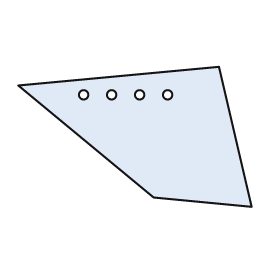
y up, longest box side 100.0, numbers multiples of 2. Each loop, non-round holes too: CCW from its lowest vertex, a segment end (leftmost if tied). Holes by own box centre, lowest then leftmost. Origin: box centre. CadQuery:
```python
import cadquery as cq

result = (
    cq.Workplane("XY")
    .moveTo(50.0, -30.0)
    .lineTo(36.0, 30.0)
    .lineTo(-50.0, 22.0)
    .lineTo(8.0, -26.0)
    .close()
    .moveTo(-22.0, 18.0)
    .circle(2.0)
    .moveTo(-10.0, 18.0)
    .circle(2.0)
    .moveTo(2.0, 18.0)
    .circle(2.0)
    .moveTo(14.0, 18.0)
    .circle(2.0)
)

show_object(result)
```